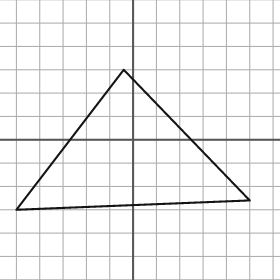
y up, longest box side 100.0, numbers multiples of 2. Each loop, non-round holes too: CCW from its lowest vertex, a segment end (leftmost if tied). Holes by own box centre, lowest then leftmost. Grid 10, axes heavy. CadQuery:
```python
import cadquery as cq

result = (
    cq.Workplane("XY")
    .moveTo(-50.0, -30.0)
    .lineTo(50.0, -26.0)
    .lineTo(-4.0, 30.0)
    .close()
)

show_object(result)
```